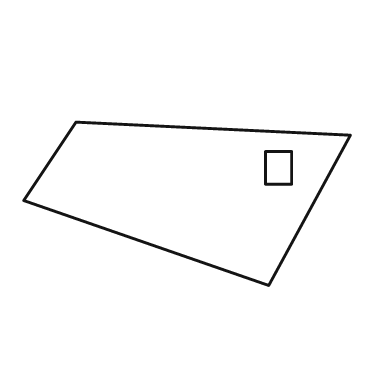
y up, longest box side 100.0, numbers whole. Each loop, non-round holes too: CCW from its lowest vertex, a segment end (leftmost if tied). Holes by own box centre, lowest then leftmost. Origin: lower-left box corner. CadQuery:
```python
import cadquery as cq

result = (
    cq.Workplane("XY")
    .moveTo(75.0, 0.0)
    .lineTo(100.0, 46.0)
    .lineTo(16.0, 50.0)
    .lineTo(0.0, 26.0)
    .close()
    .moveTo(74.0, 31.0)
    .lineTo(82.0, 31.0)
    .lineTo(82.0, 41.0)
    .lineTo(74.0, 41.0)
    .close()
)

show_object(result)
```